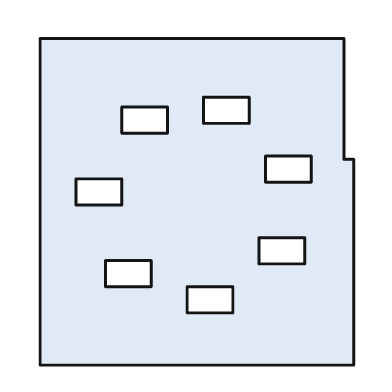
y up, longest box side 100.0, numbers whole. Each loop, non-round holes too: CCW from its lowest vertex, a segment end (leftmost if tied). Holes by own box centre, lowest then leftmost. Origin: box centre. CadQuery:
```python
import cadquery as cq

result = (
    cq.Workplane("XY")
    .moveTo(-48.0, -50.0)
    .lineTo(48.0, -50.0)
    .lineTo(48.0, 13.0)
    .lineTo(45.0, 13.0)
    .lineTo(45.0, 50.0)
    .lineTo(-48.0, 50.0)
    .close()
    .moveTo(-3.0, -34.0)
    .lineTo(11.0, -34.0)
    .lineTo(11.0, -26.0)
    .lineTo(-3.0, -26.0)
    .close()
    .moveTo(-28.0, -26.0)
    .lineTo(-14.0, -26.0)
    .lineTo(-14.0, -18.0)
    .lineTo(-28.0, -18.0)
    .close()
    .moveTo(19.0, -19.0)
    .lineTo(33.0, -19.0)
    .lineTo(33.0, -11.0)
    .lineTo(19.0, -11.0)
    .close()
    .moveTo(-37.0, -1.0)
    .lineTo(-23.0, -1.0)
    .lineTo(-23.0, 7.0)
    .lineTo(-37.0, 7.0)
    .close()
    .moveTo(21.0, 6.0)
    .lineTo(35.0, 6.0)
    .lineTo(35.0, 14.0)
    .lineTo(21.0, 14.0)
    .close()
    .moveTo(-23.0, 21.0)
    .lineTo(-9.0, 21.0)
    .lineTo(-9.0, 29.0)
    .lineTo(-23.0, 29.0)
    .close()
    .moveTo(2.0, 24.0)
    .lineTo(16.0, 24.0)
    .lineTo(16.0, 32.0)
    .lineTo(2.0, 32.0)
    .close()
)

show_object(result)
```